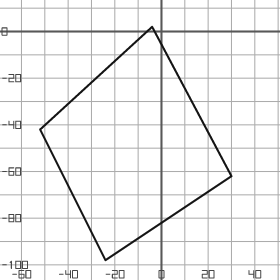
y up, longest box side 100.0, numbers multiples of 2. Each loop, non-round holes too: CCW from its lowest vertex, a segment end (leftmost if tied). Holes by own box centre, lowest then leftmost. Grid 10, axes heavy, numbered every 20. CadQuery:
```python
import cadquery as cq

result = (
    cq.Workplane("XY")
    .moveTo(-24.0, -98.0)
    .lineTo(30.0, -62.0)
    .lineTo(-4.0, 2.0)
    .lineTo(-52.0, -42.0)
    .close()
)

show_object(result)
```